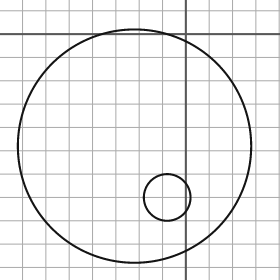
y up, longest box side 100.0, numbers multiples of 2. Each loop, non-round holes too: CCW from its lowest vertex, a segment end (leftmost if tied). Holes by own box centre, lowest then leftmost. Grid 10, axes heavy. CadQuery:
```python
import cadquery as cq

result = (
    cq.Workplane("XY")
    .moveTo(-22.0, -48.0)
    .circle(50.0)
    .moveTo(-8.0, -70.0)
    .circle(10.0)
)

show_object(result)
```